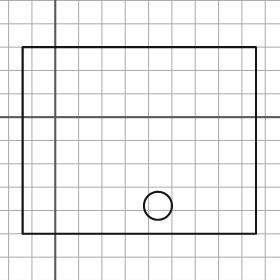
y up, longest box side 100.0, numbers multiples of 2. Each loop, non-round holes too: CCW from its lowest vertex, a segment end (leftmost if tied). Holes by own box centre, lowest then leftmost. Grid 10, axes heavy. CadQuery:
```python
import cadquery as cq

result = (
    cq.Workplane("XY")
    .moveTo(-14.0, -50.0)
    .lineTo(86.0, -50.0)
    .lineTo(86.0, 30.0)
    .lineTo(-14.0, 30.0)
    .close()
    .moveTo(44.0, -38.0)
    .circle(6.0)
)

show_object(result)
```